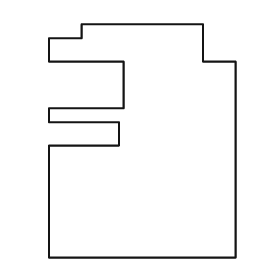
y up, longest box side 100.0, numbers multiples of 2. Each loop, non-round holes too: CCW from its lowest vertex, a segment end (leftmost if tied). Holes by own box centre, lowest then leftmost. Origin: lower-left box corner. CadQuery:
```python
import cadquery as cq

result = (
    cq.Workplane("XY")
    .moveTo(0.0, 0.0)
    .lineTo(80.0, 0.0)
    .lineTo(80.0, 84.0)
    .lineTo(66.0, 84.0)
    .lineTo(66.0, 100.0)
    .lineTo(14.0, 100.0)
    .lineTo(14.0, 94.0)
    .lineTo(0.0, 94.0)
    .lineTo(0.0, 84.0)
    .lineTo(32.0, 84.0)
    .lineTo(32.0, 64.0)
    .lineTo(0.0, 64.0)
    .lineTo(0.0, 58.0)
    .lineTo(30.0, 58.0)
    .lineTo(30.0, 48.0)
    .lineTo(0.0, 48.0)
    .close()
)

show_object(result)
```